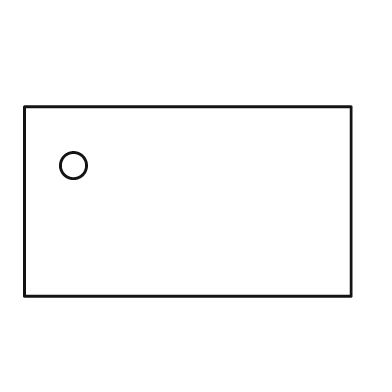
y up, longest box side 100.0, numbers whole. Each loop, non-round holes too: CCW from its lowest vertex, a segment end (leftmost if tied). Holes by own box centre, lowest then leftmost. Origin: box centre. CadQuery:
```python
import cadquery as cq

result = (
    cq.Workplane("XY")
    .moveTo(-50.0, -29.0)
    .lineTo(50.0, -29.0)
    .lineTo(50.0, 29.0)
    .lineTo(-50.0, 29.0)
    .close()
    .moveTo(-35.0, 11.0)
    .circle(4.0)
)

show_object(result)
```